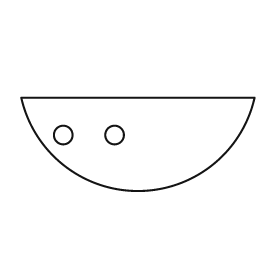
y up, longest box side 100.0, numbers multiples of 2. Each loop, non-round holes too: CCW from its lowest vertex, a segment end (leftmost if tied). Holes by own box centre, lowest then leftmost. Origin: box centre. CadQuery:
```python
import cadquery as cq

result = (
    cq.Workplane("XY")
    .moveTo(-50.0, 20.0)
    .threePointArc((0.0, -20.0), (50.0, 20.0))
    .close()
    .moveTo(-32.0, 4.0)
    .circle(4.0)
    .moveTo(-10.0, 4.0)
    .circle(4.0)
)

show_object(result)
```